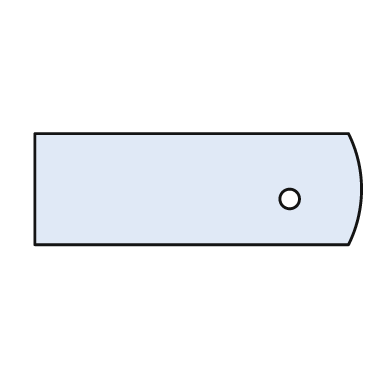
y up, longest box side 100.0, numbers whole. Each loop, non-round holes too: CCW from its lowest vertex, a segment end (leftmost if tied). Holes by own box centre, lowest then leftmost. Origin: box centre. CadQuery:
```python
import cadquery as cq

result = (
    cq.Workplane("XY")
    .moveTo(-50.0, -17.0)
    .lineTo(46.0, -17.0)
    .threePointArc((50.0, 0.0), (46.0, 17.0))
    .lineTo(-50.0, 17.0)
    .close()
    .moveTo(28.0, -3.0)
    .circle(3.0)
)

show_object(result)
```